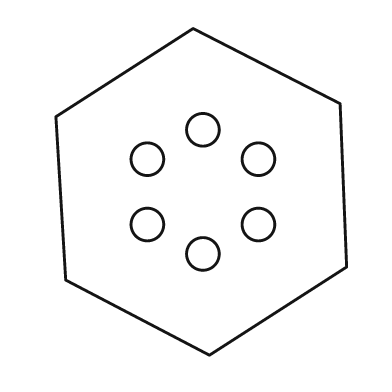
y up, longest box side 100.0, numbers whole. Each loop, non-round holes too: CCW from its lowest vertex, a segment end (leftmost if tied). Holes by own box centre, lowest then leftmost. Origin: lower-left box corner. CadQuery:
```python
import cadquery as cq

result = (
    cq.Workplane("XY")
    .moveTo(47.0, 0.0)
    .lineTo(89.0, 27.0)
    .lineTo(87.0, 77.0)
    .lineTo(42.0, 100.0)
    .lineTo(0.0, 73.0)
    .lineTo(3.0, 23.0)
    .close()
    .moveTo(45.0, 31.0)
    .circle(5.0)
    .moveTo(28.0, 40.0)
    .circle(5.0)
    .moveTo(62.0, 40.0)
    .circle(5.0)
    .moveTo(28.0, 60.0)
    .circle(5.0)
    .moveTo(62.0, 60.0)
    .circle(5.0)
    .moveTo(45.0, 69.0)
    .circle(5.0)
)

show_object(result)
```